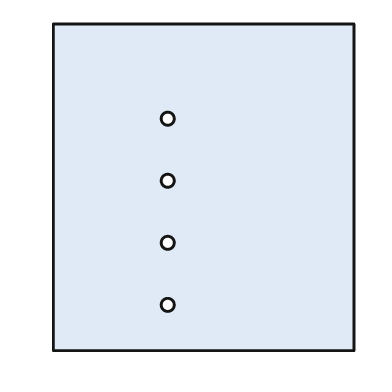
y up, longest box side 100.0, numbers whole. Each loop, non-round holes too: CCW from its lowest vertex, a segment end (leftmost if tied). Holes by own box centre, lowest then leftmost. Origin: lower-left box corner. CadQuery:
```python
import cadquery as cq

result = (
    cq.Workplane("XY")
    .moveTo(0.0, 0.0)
    .lineTo(92.0, 0.0)
    .lineTo(92.0, 100.0)
    .lineTo(0.0, 100.0)
    .close()
    .moveTo(35.0, 14.0)
    .circle(2.0)
    .moveTo(35.0, 33.0)
    .circle(2.0)
    .moveTo(35.0, 52.0)
    .circle(2.0)
    .moveTo(35.0, 71.0)
    .circle(2.0)
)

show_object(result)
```